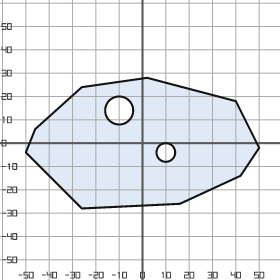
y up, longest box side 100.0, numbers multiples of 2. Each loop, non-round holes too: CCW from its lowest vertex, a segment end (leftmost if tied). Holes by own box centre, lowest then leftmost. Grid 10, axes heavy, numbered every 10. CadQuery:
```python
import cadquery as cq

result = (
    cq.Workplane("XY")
    .moveTo(-26.0, -28.0)
    .lineTo(16.0, -26.0)
    .lineTo(42.0, -14.0)
    .lineTo(50.0, -2.0)
    .lineTo(40.0, 18.0)
    .lineTo(2.0, 28.0)
    .lineTo(-26.0, 24.0)
    .lineTo(-46.0, 6.0)
    .lineTo(-50.0, -4.0)
    .close()
    .moveTo(10.0, -4.0)
    .circle(4.0)
    .moveTo(-10.0, 14.0)
    .circle(6.0)
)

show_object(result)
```